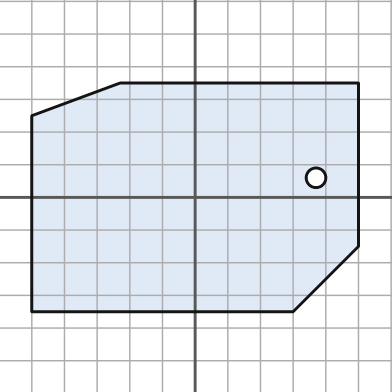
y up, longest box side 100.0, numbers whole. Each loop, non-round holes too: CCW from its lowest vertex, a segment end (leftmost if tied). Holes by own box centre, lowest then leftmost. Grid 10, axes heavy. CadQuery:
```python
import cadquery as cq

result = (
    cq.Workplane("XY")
    .moveTo(-50.0, -35.0)
    .lineTo(30.0, -35.0)
    .lineTo(50.0, -15.0)
    .lineTo(50.0, 35.0)
    .lineTo(-23.0, 35.0)
    .lineTo(-50.0, 25.0)
    .close()
    .moveTo(37.0, 6.0)
    .circle(3.0)
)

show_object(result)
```